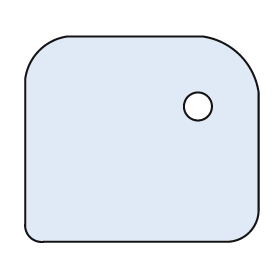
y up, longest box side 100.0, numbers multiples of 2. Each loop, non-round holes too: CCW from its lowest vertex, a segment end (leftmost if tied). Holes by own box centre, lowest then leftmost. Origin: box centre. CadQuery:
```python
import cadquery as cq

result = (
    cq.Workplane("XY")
    .moveTo(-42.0, -44.0)
    .lineTo(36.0, -44.0)
    .threePointArc((46.0, -40.0), (50.0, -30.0))
    .lineTo(50.0, 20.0)
    .threePointArc((42.0, 36.0), (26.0, 44.0))
    .lineTo(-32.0, 44.0)
    .threePointArc((-44.0, 38.0), (-50.0, 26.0))
    .lineTo(-50.0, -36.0)
    .threePointArc((-48.0, -42.0), (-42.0, -44.0))
    .close()
    .moveTo(24.0, 14.0)
    .circle(6.0)
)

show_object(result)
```